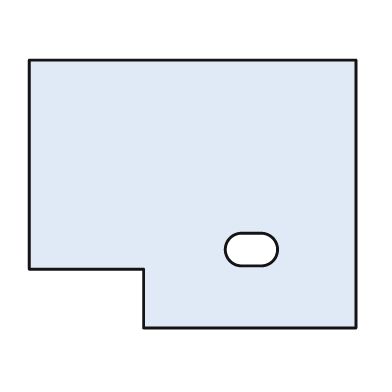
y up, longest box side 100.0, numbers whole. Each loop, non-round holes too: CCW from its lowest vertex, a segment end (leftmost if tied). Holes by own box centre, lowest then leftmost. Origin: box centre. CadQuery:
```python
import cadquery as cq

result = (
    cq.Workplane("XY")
    .moveTo(-15.0, -41.0)
    .lineTo(50.0, -41.0)
    .lineTo(50.0, 41.0)
    .lineTo(-50.0, 41.0)
    .lineTo(-50.0, -23.0)
    .lineTo(-15.0, -23.0)
    .close()
    .moveTo(15.0, -22.0)
    .lineTo(21.0, -22.0)
    .threePointArc((26.0, -17.0), (21.0, -12.0))
    .lineTo(15.0, -12.0)
    .threePointArc((10.0, -17.0), (15.0, -22.0))
    .close()
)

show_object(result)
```